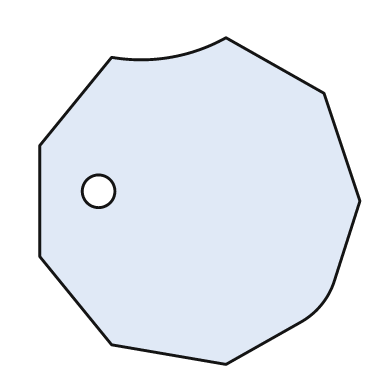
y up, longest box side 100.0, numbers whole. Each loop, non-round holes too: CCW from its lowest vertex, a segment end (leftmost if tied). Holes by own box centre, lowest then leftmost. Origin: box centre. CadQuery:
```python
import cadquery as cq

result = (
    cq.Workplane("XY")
    .moveTo(8.0, -50.0)
    .lineTo(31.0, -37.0)
    .threePointArc((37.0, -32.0), (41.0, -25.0))
    .lineTo(49.0, 0.0)
    .lineTo(38.0, 33.0)
    .lineTo(8.0, 50.0)
    .threePointArc((-9.0, 44.0), (-27.0, 44.0))
    .lineTo(-49.0, 17.0)
    .lineTo(-49.0, -17.0)
    .lineTo(-27.0, -44.0)
    .close()
    .moveTo(-31.0, 3.0)
    .circle(5.0)
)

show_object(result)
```